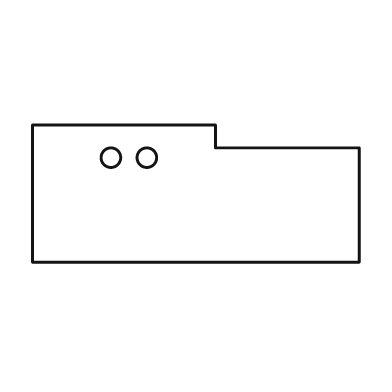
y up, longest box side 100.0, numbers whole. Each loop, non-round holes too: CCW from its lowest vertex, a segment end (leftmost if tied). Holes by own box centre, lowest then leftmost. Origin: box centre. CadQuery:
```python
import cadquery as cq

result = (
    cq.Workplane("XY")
    .moveTo(-50.0, -21.0)
    .lineTo(50.0, -21.0)
    .lineTo(50.0, 14.0)
    .lineTo(6.0, 14.0)
    .lineTo(6.0, 21.0)
    .lineTo(-50.0, 21.0)
    .close()
    .moveTo(-26.0, 11.0)
    .circle(3.0)
    .moveTo(-15.0, 11.0)
    .circle(3.0)
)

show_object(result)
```